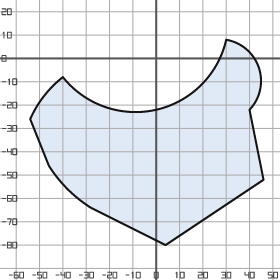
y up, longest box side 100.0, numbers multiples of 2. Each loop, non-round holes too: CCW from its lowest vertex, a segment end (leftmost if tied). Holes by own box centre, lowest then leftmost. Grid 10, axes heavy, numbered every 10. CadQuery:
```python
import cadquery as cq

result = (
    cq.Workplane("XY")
    .moveTo(4.0, -80.0)
    .lineTo(46.0, -52.0)
    .lineTo(40.0, -22.0)
    .threePointArc((44.0, -4.0), (30.0, 8.0))
    .threePointArc((0.0, -22.0), (-40.0, -8.0))
    .threePointArc((-48.0, -16.0), (-54.0, -26.0))
    .lineTo(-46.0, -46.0)
    .threePointArc((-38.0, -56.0), (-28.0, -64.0))
    .close()
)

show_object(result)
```